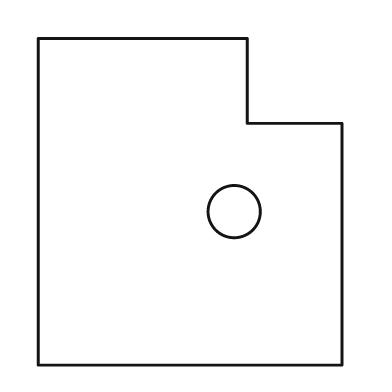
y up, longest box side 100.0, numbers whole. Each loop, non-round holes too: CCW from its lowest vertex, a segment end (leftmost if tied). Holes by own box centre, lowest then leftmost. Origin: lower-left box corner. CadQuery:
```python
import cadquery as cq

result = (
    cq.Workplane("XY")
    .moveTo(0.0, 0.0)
    .lineTo(93.0, 0.0)
    .lineTo(93.0, 74.0)
    .lineTo(64.0, 74.0)
    .lineTo(64.0, 100.0)
    .lineTo(0.0, 100.0)
    .close()
    .moveTo(60.0, 47.0)
    .circle(8.0)
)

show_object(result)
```